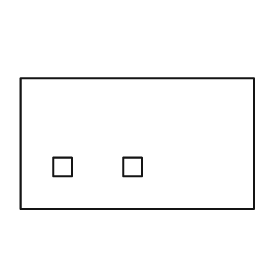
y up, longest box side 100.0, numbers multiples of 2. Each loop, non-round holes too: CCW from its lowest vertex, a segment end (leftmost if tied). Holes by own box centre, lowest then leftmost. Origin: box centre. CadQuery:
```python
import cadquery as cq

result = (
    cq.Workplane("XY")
    .moveTo(-50.0, -28.0)
    .lineTo(50.0, -28.0)
    .lineTo(50.0, 28.0)
    .lineTo(-50.0, 28.0)
    .close()
    .moveTo(-36.0, -14.0)
    .lineTo(-28.0, -14.0)
    .lineTo(-28.0, -6.0)
    .lineTo(-36.0, -6.0)
    .close()
    .moveTo(-6.0, -14.0)
    .lineTo(2.0, -14.0)
    .lineTo(2.0, -6.0)
    .lineTo(-6.0, -6.0)
    .close()
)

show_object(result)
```